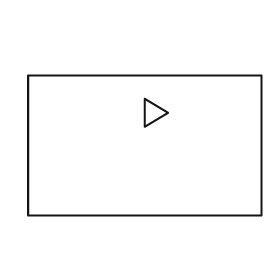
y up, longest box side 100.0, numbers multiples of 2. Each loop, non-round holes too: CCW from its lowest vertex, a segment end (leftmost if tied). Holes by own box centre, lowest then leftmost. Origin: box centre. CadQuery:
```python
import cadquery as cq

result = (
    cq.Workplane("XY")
    .moveTo(-50.0, -30.0)
    .lineTo(50.0, -30.0)
    .lineTo(50.0, 30.0)
    .lineTo(-50.0, 30.0)
    .close()
    .moveTo(0.0, 8.0)
    .lineTo(10.0, 14.0)
    .lineTo(0.0, 20.0)
    .close()
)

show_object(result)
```